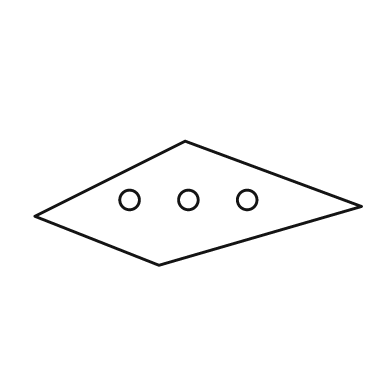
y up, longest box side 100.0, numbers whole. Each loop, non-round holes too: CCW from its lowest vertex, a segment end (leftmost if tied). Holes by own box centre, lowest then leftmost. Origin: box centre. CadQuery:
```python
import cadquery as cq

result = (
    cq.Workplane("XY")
    .moveTo(-12.0, -19.0)
    .lineTo(50.0, -1.0)
    .lineTo(-4.0, 19.0)
    .lineTo(-50.0, -4.0)
    .close()
    .moveTo(-21.0, 1.0)
    .circle(3.0)
    .moveTo(-3.0, 1.0)
    .circle(3.0)
    .moveTo(15.0, 1.0)
    .circle(3.0)
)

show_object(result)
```